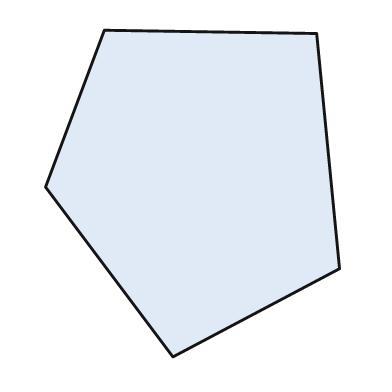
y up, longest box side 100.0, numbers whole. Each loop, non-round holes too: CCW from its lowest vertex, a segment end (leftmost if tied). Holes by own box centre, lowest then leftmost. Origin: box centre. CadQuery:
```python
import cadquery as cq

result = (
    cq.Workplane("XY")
    .moveTo(-6.0, -50.0)
    .lineTo(45.0, -23.0)
    .lineTo(38.0, 49.0)
    .lineTo(-27.0, 50.0)
    .lineTo(-45.0, 2.0)
    .close()
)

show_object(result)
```